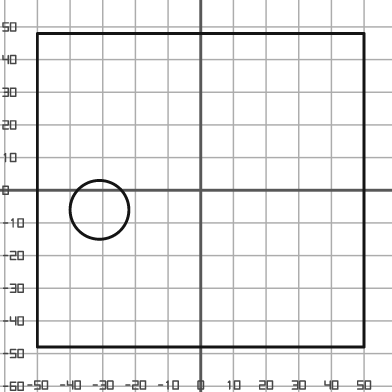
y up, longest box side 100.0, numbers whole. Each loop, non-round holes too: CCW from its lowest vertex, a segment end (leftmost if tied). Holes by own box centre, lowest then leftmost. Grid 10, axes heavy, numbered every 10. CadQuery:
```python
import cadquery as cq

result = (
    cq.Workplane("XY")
    .moveTo(-50.0, -48.0)
    .lineTo(50.0, -48.0)
    .lineTo(50.0, 48.0)
    .lineTo(-50.0, 48.0)
    .close()
    .moveTo(-31.0, -6.0)
    .circle(9.0)
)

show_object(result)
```